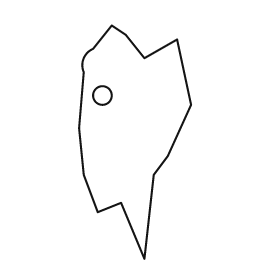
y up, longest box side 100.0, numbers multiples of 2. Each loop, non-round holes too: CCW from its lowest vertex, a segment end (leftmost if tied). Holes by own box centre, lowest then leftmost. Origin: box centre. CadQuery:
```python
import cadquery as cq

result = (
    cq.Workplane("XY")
    .moveTo(4.0, -50.0)
    .lineTo(8.0, -14.0)
    .lineTo(14.0, -6.0)
    .lineTo(24.0, 16.0)
    .lineTo(18.0, 44.0)
    .lineTo(4.0, 36.0)
    .lineTo(-4.0, 46.0)
    .lineTo(-10.0, 50.0)
    .lineTo(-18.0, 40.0)
    .threePointArc((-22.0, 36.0), (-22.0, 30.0))
    .lineTo(-24.0, 6.0)
    .lineTo(-22.0, -14.0)
    .lineTo(-16.0, -30.0)
    .lineTo(-6.0, -26.0)
    .close()
    .moveTo(-14.0, 20.0)
    .circle(4.0)
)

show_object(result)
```